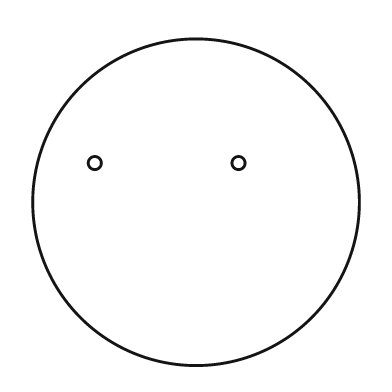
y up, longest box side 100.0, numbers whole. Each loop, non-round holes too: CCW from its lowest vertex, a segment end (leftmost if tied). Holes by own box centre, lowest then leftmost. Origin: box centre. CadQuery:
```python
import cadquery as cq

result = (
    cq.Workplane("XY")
    .moveTo(0.0, 0.0)
    .circle(50.0)
    .moveTo(-31.0, 12.0)
    .circle(2.0)
    .moveTo(13.0, 12.0)
    .circle(2.0)
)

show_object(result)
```